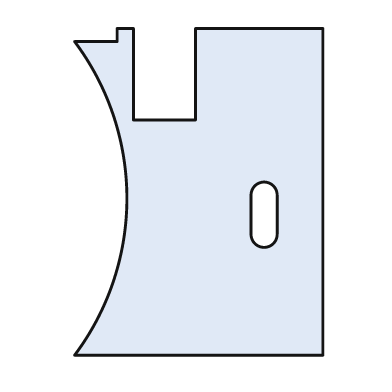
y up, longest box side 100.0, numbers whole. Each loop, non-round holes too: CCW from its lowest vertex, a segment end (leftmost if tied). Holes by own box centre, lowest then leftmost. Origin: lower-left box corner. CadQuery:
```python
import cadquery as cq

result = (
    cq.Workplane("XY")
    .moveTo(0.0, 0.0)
    .lineTo(76.0, 0.0)
    .lineTo(76.0, 100.0)
    .lineTo(37.0, 100.0)
    .lineTo(37.0, 72.0)
    .lineTo(18.0, 72.0)
    .lineTo(18.0, 100.0)
    .lineTo(13.0, 100.0)
    .lineTo(13.0, 96.0)
    .lineTo(0.0, 96.0)
    .threePointArc((16.0, 48.0), (0.0, 0.0))
    .close()
    .moveTo(54.0, 37.0)
    .threePointArc((58.0, 33.0), (62.0, 37.0))
    .lineTo(62.0, 49.0)
    .threePointArc((58.0, 53.0), (54.0, 49.0))
    .close()
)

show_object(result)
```